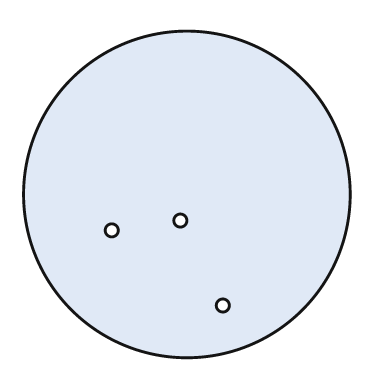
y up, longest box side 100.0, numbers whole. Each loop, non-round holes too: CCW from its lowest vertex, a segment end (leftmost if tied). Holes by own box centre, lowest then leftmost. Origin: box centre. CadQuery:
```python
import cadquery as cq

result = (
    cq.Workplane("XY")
    .moveTo(0.0, 0.0)
    .circle(50.0)
    .moveTo(11.0, -34.0)
    .circle(2.0)
    .moveTo(-23.0, -11.0)
    .circle(2.0)
    .moveTo(-2.0, -8.0)
    .circle(2.0)
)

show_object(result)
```